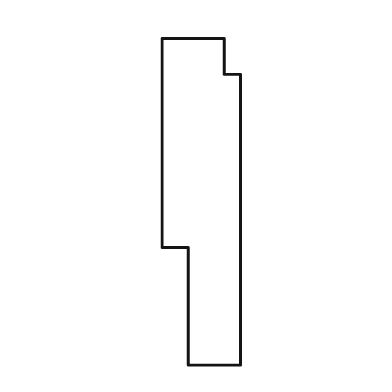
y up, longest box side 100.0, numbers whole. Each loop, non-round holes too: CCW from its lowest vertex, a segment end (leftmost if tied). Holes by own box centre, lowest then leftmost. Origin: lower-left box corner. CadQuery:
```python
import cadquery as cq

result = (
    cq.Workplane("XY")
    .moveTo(8.0, 0.0)
    .lineTo(24.0, 0.0)
    .lineTo(24.0, 89.0)
    .lineTo(19.0, 89.0)
    .lineTo(19.0, 100.0)
    .lineTo(0.0, 100.0)
    .lineTo(0.0, 36.0)
    .lineTo(8.0, 36.0)
    .close()
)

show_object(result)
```